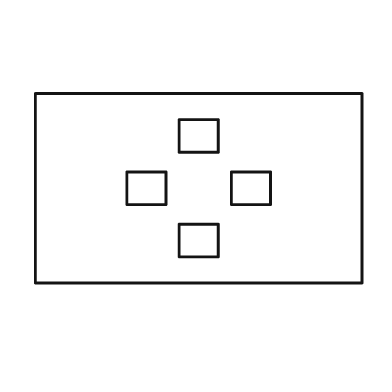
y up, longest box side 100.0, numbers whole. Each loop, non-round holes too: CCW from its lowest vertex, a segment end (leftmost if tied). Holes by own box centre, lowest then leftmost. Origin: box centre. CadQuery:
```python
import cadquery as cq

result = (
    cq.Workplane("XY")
    .moveTo(-50.0, -29.0)
    .lineTo(50.0, -29.0)
    .lineTo(50.0, 29.0)
    .lineTo(-50.0, 29.0)
    .close()
    .moveTo(-6.0, -21.0)
    .lineTo(6.0, -21.0)
    .lineTo(6.0, -11.0)
    .lineTo(-6.0, -11.0)
    .close()
    .moveTo(-22.0, -5.0)
    .lineTo(-10.0, -5.0)
    .lineTo(-10.0, 5.0)
    .lineTo(-22.0, 5.0)
    .close()
    .moveTo(10.0, -5.0)
    .lineTo(22.0, -5.0)
    .lineTo(22.0, 5.0)
    .lineTo(10.0, 5.0)
    .close()
    .moveTo(-6.0, 11.0)
    .lineTo(6.0, 11.0)
    .lineTo(6.0, 21.0)
    .lineTo(-6.0, 21.0)
    .close()
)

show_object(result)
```